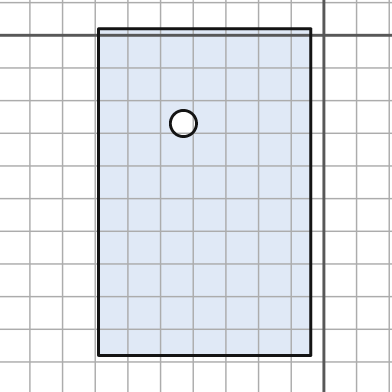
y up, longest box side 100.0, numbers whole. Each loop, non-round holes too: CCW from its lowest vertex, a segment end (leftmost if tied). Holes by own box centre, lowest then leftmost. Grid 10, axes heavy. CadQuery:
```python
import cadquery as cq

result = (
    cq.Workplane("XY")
    .moveTo(-69.0, -98.0)
    .lineTo(-4.0, -98.0)
    .lineTo(-4.0, 2.0)
    .lineTo(-69.0, 2.0)
    .close()
    .moveTo(-43.0, -27.0)
    .circle(4.0)
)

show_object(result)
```